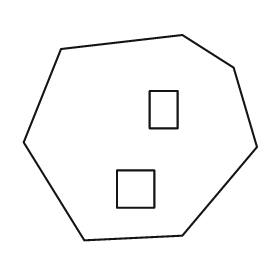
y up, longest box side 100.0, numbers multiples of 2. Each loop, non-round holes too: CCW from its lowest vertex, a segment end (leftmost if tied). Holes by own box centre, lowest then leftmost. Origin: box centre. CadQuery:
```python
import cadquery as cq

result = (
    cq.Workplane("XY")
    .moveTo(-24.0, -44.0)
    .lineTo(18.0, -42.0)
    .lineTo(50.0, -4.0)
    .lineTo(40.0, 30.0)
    .lineTo(18.0, 44.0)
    .lineTo(-34.0, 38.0)
    .lineTo(-50.0, -2.0)
    .close()
    .moveTo(-10.0, -30.0)
    .lineTo(6.0, -30.0)
    .lineTo(6.0, -14.0)
    .lineTo(-10.0, -14.0)
    .close()
    .moveTo(4.0, 4.0)
    .lineTo(16.0, 4.0)
    .lineTo(16.0, 20.0)
    .lineTo(4.0, 20.0)
    .close()
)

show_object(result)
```